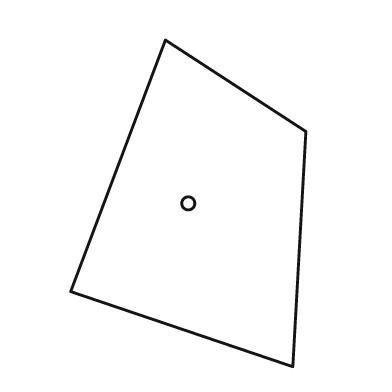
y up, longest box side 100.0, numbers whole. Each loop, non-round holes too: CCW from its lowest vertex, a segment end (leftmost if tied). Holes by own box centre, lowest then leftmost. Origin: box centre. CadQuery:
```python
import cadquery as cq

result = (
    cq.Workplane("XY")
    .moveTo(32.0, -50.0)
    .lineTo(36.0, 22.0)
    .lineTo(-7.0, 50.0)
    .lineTo(-36.0, -27.0)
    .close()
    .moveTo(0.0, 0.0)
    .circle(2.0)
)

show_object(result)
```